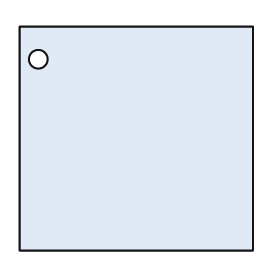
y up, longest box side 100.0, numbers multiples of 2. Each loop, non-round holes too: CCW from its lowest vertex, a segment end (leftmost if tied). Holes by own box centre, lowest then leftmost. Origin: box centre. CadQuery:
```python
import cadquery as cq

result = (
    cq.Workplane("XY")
    .moveTo(-50.0, -48.0)
    .lineTo(50.0, -48.0)
    .lineTo(50.0, 48.0)
    .lineTo(-50.0, 48.0)
    .close()
    .moveTo(-42.0, 34.0)
    .circle(4.0)
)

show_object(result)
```